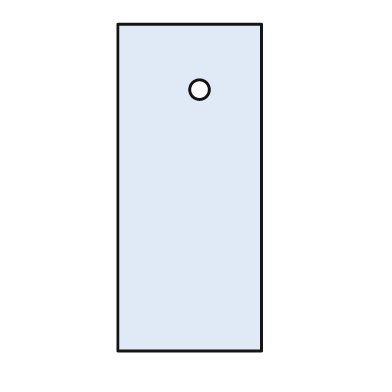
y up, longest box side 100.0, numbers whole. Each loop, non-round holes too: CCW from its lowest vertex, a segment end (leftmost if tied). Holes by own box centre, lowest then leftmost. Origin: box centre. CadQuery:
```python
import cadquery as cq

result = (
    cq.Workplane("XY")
    .moveTo(-22.0, -50.0)
    .lineTo(22.0, -50.0)
    .lineTo(22.0, 50.0)
    .lineTo(-22.0, 50.0)
    .close()
    .moveTo(3.0, 30.0)
    .circle(3.0)
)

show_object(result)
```